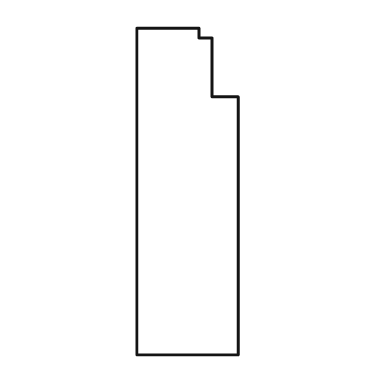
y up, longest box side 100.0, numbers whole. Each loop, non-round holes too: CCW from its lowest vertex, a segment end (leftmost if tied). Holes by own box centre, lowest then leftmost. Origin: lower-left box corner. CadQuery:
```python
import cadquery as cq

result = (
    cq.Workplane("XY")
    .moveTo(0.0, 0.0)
    .lineTo(31.0, 0.0)
    .lineTo(31.0, 79.0)
    .lineTo(23.0, 79.0)
    .lineTo(23.0, 97.0)
    .lineTo(19.0, 97.0)
    .lineTo(19.0, 100.0)
    .lineTo(0.0, 100.0)
    .close()
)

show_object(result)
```